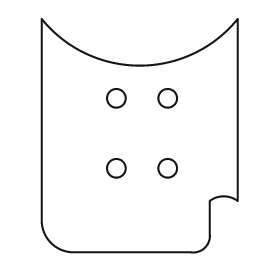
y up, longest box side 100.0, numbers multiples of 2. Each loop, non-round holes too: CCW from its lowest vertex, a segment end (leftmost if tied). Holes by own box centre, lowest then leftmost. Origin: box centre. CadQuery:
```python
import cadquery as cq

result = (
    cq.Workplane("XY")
    .moveTo(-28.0, -50.0)
    .lineTo(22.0, -50.0)
    .threePointArc((28.0, -48.0), (30.0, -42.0))
    .lineTo(30.0, -28.0)
    .threePointArc((36.0, -26.0), (42.0, -28.0))
    .lineTo(42.0, 50.0)
    .threePointArc((0.0, 30.0), (-42.0, 50.0))
    .lineTo(-42.0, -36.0)
    .threePointArc((-38.0, -46.0), (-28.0, -50.0))
    .close()
    .moveTo(-10.0, -14.0)
    .circle(4.0)
    .moveTo(12.0, -14.0)
    .circle(4.0)
    .moveTo(-10.0, 16.0)
    .circle(4.0)
    .moveTo(12.0, 16.0)
    .circle(4.0)
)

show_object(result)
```